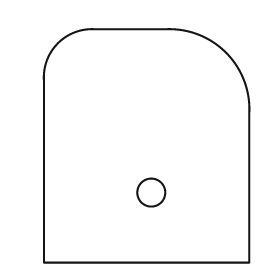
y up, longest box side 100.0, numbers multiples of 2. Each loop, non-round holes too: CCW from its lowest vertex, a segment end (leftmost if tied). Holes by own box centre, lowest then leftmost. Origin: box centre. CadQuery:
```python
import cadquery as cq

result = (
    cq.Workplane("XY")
    .moveTo(-44.0, -50.0)
    .lineTo(44.0, -50.0)
    .lineTo(44.0, 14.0)
    .threePointArc((34.0, 40.0), (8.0, 50.0))
    .lineTo(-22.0, 50.0)
    .threePointArc((-38.0, 44.0), (-44.0, 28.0))
    .close()
    .moveTo(2.0, -20.0)
    .circle(6.0)
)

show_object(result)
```